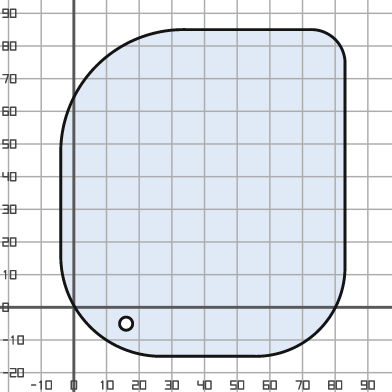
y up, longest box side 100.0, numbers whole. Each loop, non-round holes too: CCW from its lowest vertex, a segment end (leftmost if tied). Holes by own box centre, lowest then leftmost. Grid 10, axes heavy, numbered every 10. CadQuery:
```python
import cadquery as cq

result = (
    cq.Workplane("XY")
    .moveTo(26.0, -15.0)
    .lineTo(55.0, -15.0)
    .threePointArc((75.0, -7.0), (83.0, 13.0))
    .lineTo(83.0, 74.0)
    .threePointArc((80.0, 82.0), (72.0, 85.0))
    .lineTo(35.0, 85.0)
    .threePointArc((7.0, 74.0), (-4.0, 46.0))
    .lineTo(-4.0, 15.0)
    .threePointArc((5.0, -6.0), (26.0, -15.0))
    .close()
    .moveTo(16.0, -5.0)
    .circle(2.0)
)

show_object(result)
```